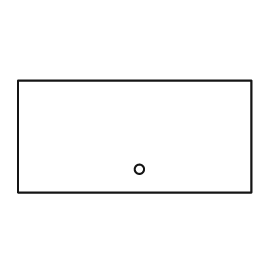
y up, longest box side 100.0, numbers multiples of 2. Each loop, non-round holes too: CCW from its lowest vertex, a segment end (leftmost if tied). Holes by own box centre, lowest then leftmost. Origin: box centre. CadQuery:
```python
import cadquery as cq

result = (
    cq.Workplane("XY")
    .moveTo(-50.0, -24.0)
    .lineTo(50.0, -24.0)
    .lineTo(50.0, 24.0)
    .lineTo(-50.0, 24.0)
    .close()
    .moveTo(2.0, -14.0)
    .circle(2.0)
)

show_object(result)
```